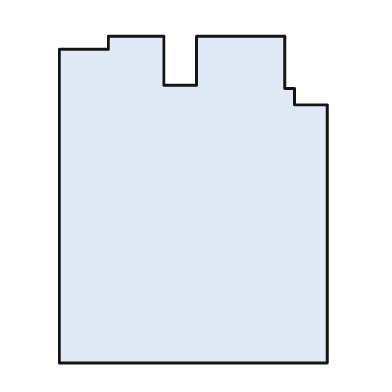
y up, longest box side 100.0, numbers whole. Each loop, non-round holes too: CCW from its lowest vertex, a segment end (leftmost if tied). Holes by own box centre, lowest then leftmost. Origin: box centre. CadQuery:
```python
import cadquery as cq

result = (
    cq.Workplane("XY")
    .moveTo(-41.0, -50.0)
    .lineTo(41.0, -50.0)
    .lineTo(41.0, 29.0)
    .lineTo(31.0, 29.0)
    .lineTo(31.0, 34.0)
    .lineTo(28.0, 34.0)
    .lineTo(28.0, 50.0)
    .lineTo(1.0, 50.0)
    .lineTo(1.0, 35.0)
    .lineTo(-9.0, 35.0)
    .lineTo(-9.0, 50.0)
    .lineTo(-26.0, 50.0)
    .lineTo(-26.0, 46.0)
    .lineTo(-41.0, 46.0)
    .close()
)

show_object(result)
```